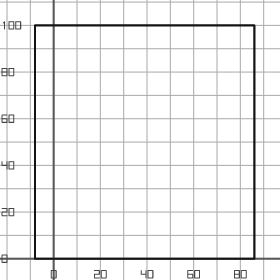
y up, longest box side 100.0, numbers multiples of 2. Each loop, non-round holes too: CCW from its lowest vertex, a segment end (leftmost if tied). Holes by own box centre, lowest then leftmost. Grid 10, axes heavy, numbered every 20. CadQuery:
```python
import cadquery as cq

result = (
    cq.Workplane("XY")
    .moveTo(-8.0, 0.0)
    .lineTo(86.0, 0.0)
    .lineTo(86.0, 100.0)
    .lineTo(-8.0, 100.0)
    .close()
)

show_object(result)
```